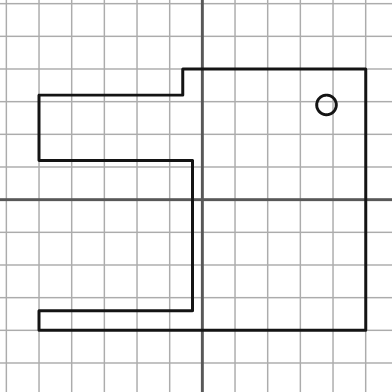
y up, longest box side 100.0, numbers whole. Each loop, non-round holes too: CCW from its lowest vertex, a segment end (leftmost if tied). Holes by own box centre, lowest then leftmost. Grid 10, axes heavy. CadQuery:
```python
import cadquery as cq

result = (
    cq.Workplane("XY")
    .moveTo(-50.0, -40.0)
    .lineTo(50.0, -40.0)
    .lineTo(50.0, 40.0)
    .lineTo(-6.0, 40.0)
    .lineTo(-6.0, 32.0)
    .lineTo(-50.0, 32.0)
    .lineTo(-50.0, 12.0)
    .lineTo(-3.0, 12.0)
    .lineTo(-3.0, -34.0)
    .lineTo(-50.0, -34.0)
    .close()
    .moveTo(38.0, 29.0)
    .circle(3.0)
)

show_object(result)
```